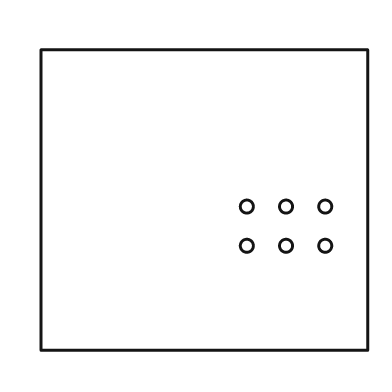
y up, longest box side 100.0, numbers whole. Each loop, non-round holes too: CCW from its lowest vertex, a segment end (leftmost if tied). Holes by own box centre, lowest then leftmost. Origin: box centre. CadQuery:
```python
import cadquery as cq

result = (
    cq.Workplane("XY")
    .moveTo(-50.0, -46.0)
    .lineTo(50.0, -46.0)
    .lineTo(50.0, 46.0)
    .lineTo(-50.0, 46.0)
    .close()
    .moveTo(13.0, -14.0)
    .circle(2.0)
    .moveTo(25.0, -14.0)
    .circle(2.0)
    .moveTo(37.0, -14.0)
    .circle(2.0)
    .moveTo(13.0, -2.0)
    .circle(2.0)
    .moveTo(25.0, -2.0)
    .circle(2.0)
    .moveTo(37.0, -2.0)
    .circle(2.0)
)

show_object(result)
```